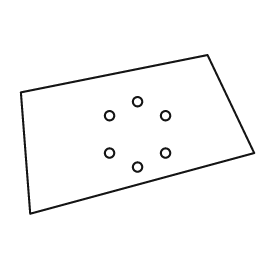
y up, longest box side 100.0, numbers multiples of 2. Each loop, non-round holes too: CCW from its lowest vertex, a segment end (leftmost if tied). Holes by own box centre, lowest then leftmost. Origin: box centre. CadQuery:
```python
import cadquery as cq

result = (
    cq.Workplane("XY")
    .moveTo(-46.0, -34.0)
    .lineTo(50.0, -8.0)
    .lineTo(30.0, 34.0)
    .lineTo(-50.0, 18.0)
    .close()
    .moveTo(0.0, -14.0)
    .circle(2.0)
    .moveTo(-12.0, -8.0)
    .circle(2.0)
    .moveTo(12.0, -8.0)
    .circle(2.0)
    .moveTo(-12.0, 8.0)
    .circle(2.0)
    .moveTo(12.0, 8.0)
    .circle(2.0)
    .moveTo(0.0, 14.0)
    .circle(2.0)
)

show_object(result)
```